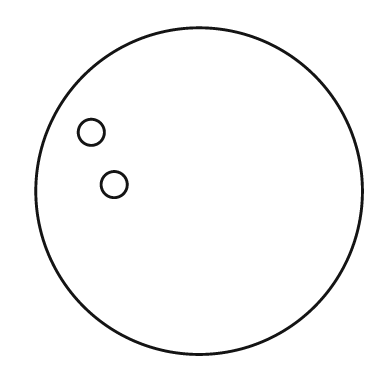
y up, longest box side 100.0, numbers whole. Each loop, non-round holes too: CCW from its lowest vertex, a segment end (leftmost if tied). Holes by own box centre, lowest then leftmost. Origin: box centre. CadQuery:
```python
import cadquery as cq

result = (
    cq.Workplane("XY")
    .moveTo(0.0, 0.0)
    .circle(50.0)
    .moveTo(-26.0, 2.0)
    .circle(4.0)
    .moveTo(-33.0, 18.0)
    .circle(4.0)
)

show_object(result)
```